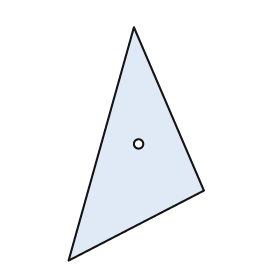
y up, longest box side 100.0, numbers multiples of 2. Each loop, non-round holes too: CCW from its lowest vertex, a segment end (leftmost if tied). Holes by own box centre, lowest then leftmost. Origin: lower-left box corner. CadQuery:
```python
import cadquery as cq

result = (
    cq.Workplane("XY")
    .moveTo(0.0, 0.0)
    .lineTo(58.0, 30.0)
    .lineTo(28.0, 100.0)
    .close()
    .moveTo(30.0, 50.0)
    .circle(2.0)
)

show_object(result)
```